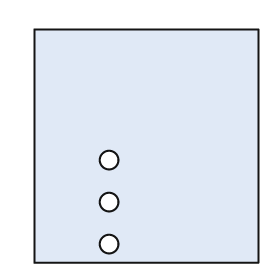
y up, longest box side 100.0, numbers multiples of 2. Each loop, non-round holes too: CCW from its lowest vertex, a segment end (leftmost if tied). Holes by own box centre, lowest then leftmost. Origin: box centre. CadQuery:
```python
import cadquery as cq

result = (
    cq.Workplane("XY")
    .moveTo(-48.0, -50.0)
    .lineTo(48.0, -50.0)
    .lineTo(48.0, 50.0)
    .lineTo(-48.0, 50.0)
    .close()
    .moveTo(-16.0, -42.0)
    .circle(4.0)
    .moveTo(-16.0, -24.0)
    .circle(4.0)
    .moveTo(-16.0, -6.0)
    .circle(4.0)
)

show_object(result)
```